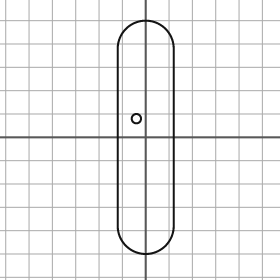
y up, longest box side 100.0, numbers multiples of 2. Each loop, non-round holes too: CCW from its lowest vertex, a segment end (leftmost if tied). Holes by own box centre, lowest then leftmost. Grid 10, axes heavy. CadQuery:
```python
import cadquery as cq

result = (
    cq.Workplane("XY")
    .moveTo(-12.0, -38.0)
    .threePointArc((0.0, -50.0), (12.0, -38.0))
    .lineTo(12.0, 38.0)
    .threePointArc((0.0, 50.0), (-12.0, 38.0))
    .close()
    .moveTo(-4.0, 8.0)
    .circle(2.0)
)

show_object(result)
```